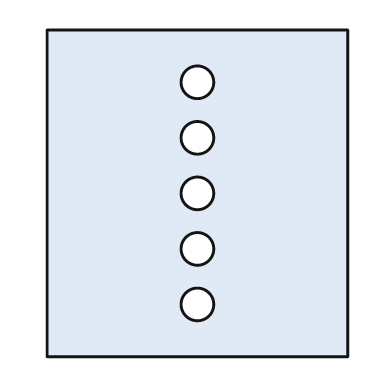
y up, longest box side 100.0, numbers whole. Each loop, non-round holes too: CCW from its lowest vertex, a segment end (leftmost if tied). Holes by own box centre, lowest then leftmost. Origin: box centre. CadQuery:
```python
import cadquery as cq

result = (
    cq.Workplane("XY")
    .moveTo(-46.0, -50.0)
    .lineTo(46.0, -50.0)
    .lineTo(46.0, 50.0)
    .lineTo(-46.0, 50.0)
    .close()
    .moveTo(0.0, -34.0)
    .circle(5.0)
    .moveTo(0.0, -17.0)
    .circle(5.0)
    .moveTo(0.0, 0.0)
    .circle(5.0)
    .moveTo(0.0, 17.0)
    .circle(5.0)
    .moveTo(0.0, 34.0)
    .circle(5.0)
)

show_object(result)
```